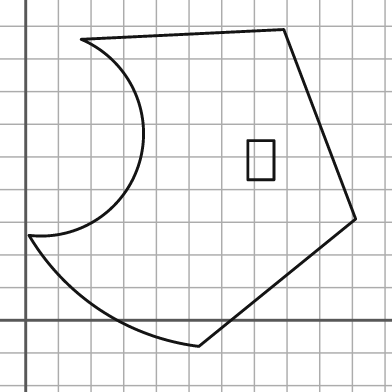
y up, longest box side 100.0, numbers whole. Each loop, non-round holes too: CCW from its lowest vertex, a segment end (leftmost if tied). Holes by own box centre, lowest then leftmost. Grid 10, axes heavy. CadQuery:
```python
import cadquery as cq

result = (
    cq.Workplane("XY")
    .moveTo(53.0, -8.0)
    .lineTo(101.0, 31.0)
    .lineTo(79.0, 89.0)
    .lineTo(17.0, 86.0)
    .threePointArc((35.0, 49.0), (1.0, 26.0))
    .threePointArc((23.0, 3.0), (53.0, -8.0))
    .close()
    .moveTo(68.0, 43.0)
    .lineTo(76.0, 43.0)
    .lineTo(76.0, 55.0)
    .lineTo(68.0, 55.0)
    .close()
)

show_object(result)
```